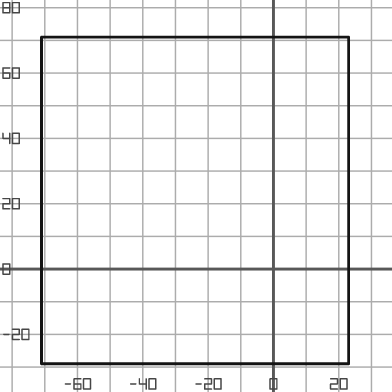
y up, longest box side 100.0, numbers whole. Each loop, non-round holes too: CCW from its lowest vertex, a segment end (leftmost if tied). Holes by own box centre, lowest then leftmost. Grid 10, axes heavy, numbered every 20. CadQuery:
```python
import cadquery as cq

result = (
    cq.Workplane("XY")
    .moveTo(-71.0, -29.0)
    .lineTo(23.0, -29.0)
    .lineTo(23.0, 71.0)
    .lineTo(-71.0, 71.0)
    .close()
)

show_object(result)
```